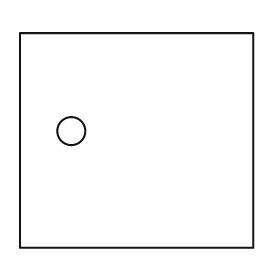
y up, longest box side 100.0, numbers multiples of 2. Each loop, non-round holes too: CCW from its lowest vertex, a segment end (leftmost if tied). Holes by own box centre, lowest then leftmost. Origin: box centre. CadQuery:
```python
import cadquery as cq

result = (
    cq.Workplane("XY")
    .moveTo(-50.0, -46.0)
    .lineTo(50.0, -46.0)
    .lineTo(50.0, 46.0)
    .lineTo(-50.0, 46.0)
    .close()
    .moveTo(-28.0, 4.0)
    .circle(6.0)
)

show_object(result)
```